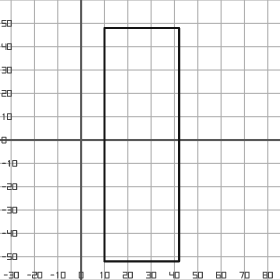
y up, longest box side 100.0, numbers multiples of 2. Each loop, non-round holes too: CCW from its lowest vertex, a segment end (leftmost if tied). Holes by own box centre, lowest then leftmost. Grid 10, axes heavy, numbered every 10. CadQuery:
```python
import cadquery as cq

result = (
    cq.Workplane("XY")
    .moveTo(10.0, -52.0)
    .lineTo(42.0, -52.0)
    .lineTo(42.0, 48.0)
    .lineTo(10.0, 48.0)
    .close()
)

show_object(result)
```